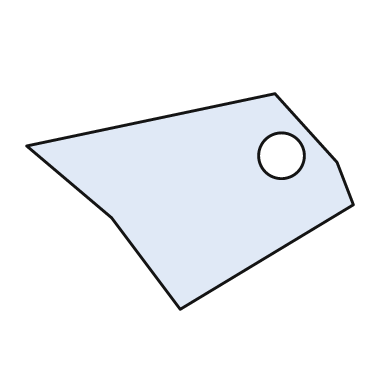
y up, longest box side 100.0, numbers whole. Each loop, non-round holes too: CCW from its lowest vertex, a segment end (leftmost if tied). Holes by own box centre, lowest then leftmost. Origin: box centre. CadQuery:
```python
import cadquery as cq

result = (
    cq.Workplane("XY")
    .moveTo(-3.0, -33.0)
    .lineTo(50.0, -1.0)
    .lineTo(45.0, 12.0)
    .lineTo(26.0, 33.0)
    .lineTo(-50.0, 17.0)
    .lineTo(-24.0, -5.0)
    .close()
    .moveTo(28.0, 14.0)
    .circle(7.0)
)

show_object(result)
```